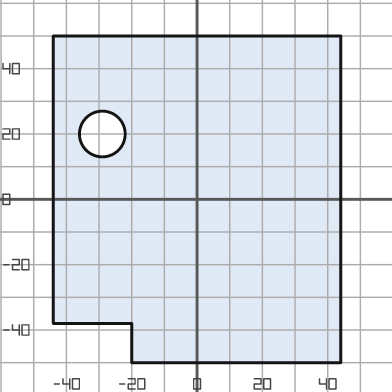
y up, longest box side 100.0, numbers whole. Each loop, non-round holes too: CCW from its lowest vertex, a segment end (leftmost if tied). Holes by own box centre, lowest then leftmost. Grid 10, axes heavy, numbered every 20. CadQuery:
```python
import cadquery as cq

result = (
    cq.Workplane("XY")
    .moveTo(-20.0, -50.0)
    .lineTo(44.0, -50.0)
    .lineTo(44.0, 50.0)
    .lineTo(-44.0, 50.0)
    .lineTo(-44.0, -38.0)
    .lineTo(-20.0, -38.0)
    .close()
    .moveTo(-29.0, 20.0)
    .circle(7.0)
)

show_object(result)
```